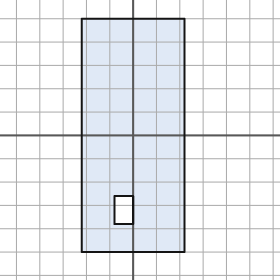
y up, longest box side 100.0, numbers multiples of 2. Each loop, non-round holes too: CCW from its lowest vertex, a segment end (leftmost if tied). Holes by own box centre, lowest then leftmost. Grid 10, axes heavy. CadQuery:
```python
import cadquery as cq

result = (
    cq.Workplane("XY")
    .moveTo(-22.0, -50.0)
    .lineTo(22.0, -50.0)
    .lineTo(22.0, 50.0)
    .lineTo(-22.0, 50.0)
    .close()
    .moveTo(-8.0, -38.0)
    .lineTo(0.0, -38.0)
    .lineTo(0.0, -26.0)
    .lineTo(-8.0, -26.0)
    .close()
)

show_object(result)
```